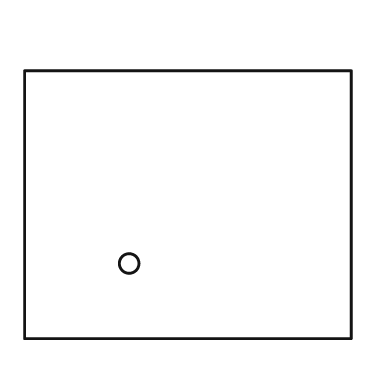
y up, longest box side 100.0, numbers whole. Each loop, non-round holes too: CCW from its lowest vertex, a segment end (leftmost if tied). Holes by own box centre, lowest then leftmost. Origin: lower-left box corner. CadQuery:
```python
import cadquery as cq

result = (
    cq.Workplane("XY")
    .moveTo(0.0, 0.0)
    .lineTo(100.0, 0.0)
    .lineTo(100.0, 82.0)
    .lineTo(0.0, 82.0)
    .close()
    .moveTo(32.0, 23.0)
    .circle(3.0)
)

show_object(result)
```